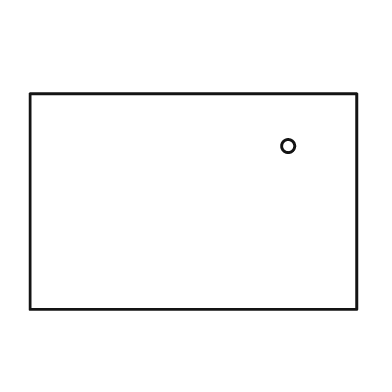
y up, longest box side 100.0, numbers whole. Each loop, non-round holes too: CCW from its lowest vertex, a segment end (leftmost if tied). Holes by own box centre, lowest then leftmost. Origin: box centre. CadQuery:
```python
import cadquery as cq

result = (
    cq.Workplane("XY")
    .moveTo(-50.0, -33.0)
    .lineTo(50.0, -33.0)
    .lineTo(50.0, 33.0)
    .lineTo(-50.0, 33.0)
    .close()
    .moveTo(29.0, 17.0)
    .circle(2.0)
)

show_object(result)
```